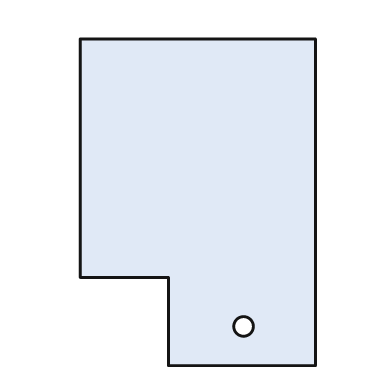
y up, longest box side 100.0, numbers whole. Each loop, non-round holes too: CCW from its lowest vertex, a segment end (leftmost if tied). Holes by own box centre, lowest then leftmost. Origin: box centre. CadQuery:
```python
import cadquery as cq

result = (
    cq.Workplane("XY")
    .moveTo(-9.0, -50.0)
    .lineTo(36.0, -50.0)
    .lineTo(36.0, 50.0)
    .lineTo(-36.0, 50.0)
    .lineTo(-36.0, -23.0)
    .lineTo(-9.0, -23.0)
    .close()
    .moveTo(14.0, -38.0)
    .circle(3.0)
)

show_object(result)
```